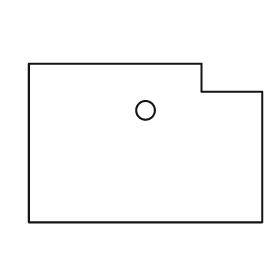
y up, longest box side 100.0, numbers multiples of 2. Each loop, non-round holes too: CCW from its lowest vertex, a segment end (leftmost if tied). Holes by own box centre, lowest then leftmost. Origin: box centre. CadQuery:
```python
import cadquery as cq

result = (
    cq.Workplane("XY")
    .moveTo(-50.0, -34.0)
    .lineTo(50.0, -34.0)
    .lineTo(50.0, 22.0)
    .lineTo(24.0, 22.0)
    .lineTo(24.0, 34.0)
    .lineTo(-50.0, 34.0)
    .close()
    .moveTo(0.0, 14.0)
    .circle(4.0)
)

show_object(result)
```